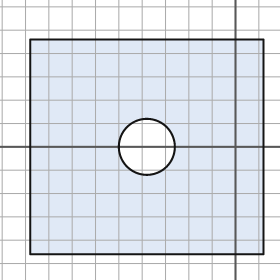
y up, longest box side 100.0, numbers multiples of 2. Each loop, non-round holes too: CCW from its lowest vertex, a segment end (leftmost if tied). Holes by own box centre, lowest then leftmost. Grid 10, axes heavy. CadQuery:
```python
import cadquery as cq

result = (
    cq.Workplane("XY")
    .moveTo(-88.0, -46.0)
    .lineTo(12.0, -46.0)
    .lineTo(12.0, 46.0)
    .lineTo(-88.0, 46.0)
    .close()
    .moveTo(-38.0, 0.0)
    .circle(12.0)
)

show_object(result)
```